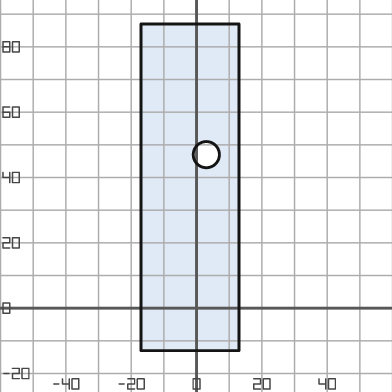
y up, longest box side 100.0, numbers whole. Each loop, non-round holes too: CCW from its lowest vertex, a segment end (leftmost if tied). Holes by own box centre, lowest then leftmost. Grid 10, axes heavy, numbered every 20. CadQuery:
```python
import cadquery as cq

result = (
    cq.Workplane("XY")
    .moveTo(-17.0, -13.0)
    .lineTo(13.0, -13.0)
    .lineTo(13.0, 87.0)
    .lineTo(-17.0, 87.0)
    .close()
    .moveTo(3.0, 47.0)
    .circle(4.0)
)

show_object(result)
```